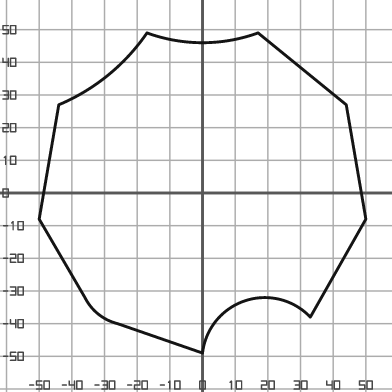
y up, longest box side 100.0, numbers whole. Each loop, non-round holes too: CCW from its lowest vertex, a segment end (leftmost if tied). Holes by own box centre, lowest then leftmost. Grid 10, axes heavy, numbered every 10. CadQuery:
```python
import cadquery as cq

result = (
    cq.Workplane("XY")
    .moveTo(0.0, -49.0)
    .threePointArc((13.0, -33.0), (33.0, -38.0))
    .lineTo(50.0, -8.0)
    .lineTo(44.0, 27.0)
    .lineTo(17.0, 49.0)
    .threePointArc((0.0, 46.0), (-17.0, 49.0))
    .threePointArc((-29.0, 36.0), (-44.0, 27.0))
    .lineTo(-50.0, -8.0)
    .lineTo(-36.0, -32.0)
    .threePointArc((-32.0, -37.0), (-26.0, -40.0))
    .close()
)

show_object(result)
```